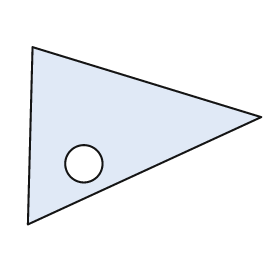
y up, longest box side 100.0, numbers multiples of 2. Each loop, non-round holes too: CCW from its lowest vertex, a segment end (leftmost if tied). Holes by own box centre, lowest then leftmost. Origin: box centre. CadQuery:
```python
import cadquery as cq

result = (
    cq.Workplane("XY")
    .moveTo(-50.0, -38.0)
    .lineTo(50.0, 8.0)
    .lineTo(-48.0, 38.0)
    .close()
    .moveTo(-26.0, -12.0)
    .circle(8.0)
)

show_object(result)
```